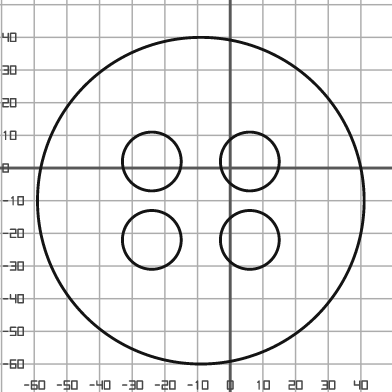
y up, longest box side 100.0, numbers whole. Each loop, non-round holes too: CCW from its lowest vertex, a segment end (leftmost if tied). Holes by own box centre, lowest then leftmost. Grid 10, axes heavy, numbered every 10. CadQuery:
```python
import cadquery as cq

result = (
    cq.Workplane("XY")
    .moveTo(-9.0, -10.0)
    .circle(50.0)
    .moveTo(-24.0, -22.0)
    .circle(9.0)
    .moveTo(6.0, -22.0)
    .circle(9.0)
    .moveTo(-24.0, 2.0)
    .circle(9.0)
    .moveTo(6.0, 2.0)
    .circle(9.0)
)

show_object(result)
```